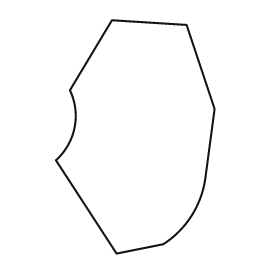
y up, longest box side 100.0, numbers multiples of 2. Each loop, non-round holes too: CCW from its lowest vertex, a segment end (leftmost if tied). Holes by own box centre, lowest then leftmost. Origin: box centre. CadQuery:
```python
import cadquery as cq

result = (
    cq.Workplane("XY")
    .moveTo(-8.0, -50.0)
    .lineTo(12.0, -46.0)
    .threePointArc((24.0, -34.0), (30.0, -18.0))
    .lineTo(34.0, 12.0)
    .lineTo(22.0, 48.0)
    .lineTo(-10.0, 50.0)
    .lineTo(-28.0, 20.0)
    .threePointArc((-26.0, 4.0), (-34.0, -10.0))
    .close()
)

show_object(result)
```